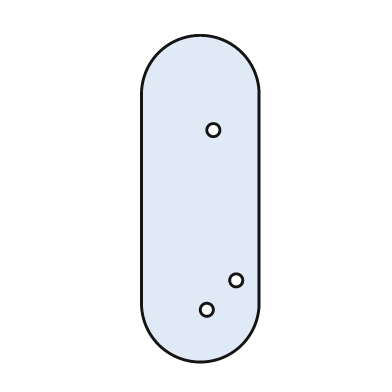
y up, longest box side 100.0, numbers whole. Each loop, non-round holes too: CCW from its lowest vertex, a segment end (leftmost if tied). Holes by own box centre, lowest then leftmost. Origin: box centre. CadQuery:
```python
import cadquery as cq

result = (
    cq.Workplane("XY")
    .moveTo(-18.0, -32.0)
    .threePointArc((0.0, -50.0), (18.0, -32.0))
    .lineTo(18.0, 32.0)
    .threePointArc((0.0, 50.0), (-18.0, 32.0))
    .close()
    .moveTo(2.0, -34.0)
    .circle(2.0)
    .moveTo(11.0, -25.0)
    .circle(2.0)
    .moveTo(4.0, 21.0)
    .circle(2.0)
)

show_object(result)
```